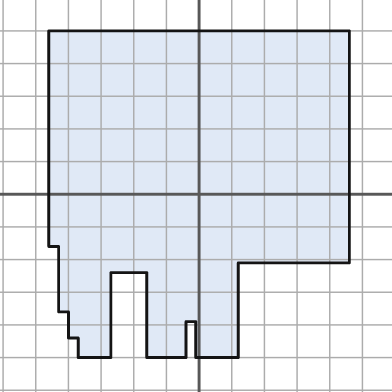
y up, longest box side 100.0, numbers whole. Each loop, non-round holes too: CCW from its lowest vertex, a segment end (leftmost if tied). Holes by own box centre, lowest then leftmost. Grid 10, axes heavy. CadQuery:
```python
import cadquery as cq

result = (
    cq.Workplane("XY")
    .moveTo(-37.0, -50.0)
    .lineTo(-27.0, -50.0)
    .lineTo(-27.0, -24.0)
    .lineTo(-16.0, -24.0)
    .lineTo(-16.0, -50.0)
    .lineTo(-4.0, -50.0)
    .lineTo(-4.0, -39.0)
    .lineTo(-1.0, -39.0)
    .lineTo(-1.0, -50.0)
    .lineTo(12.0, -50.0)
    .lineTo(12.0, -21.0)
    .lineTo(46.0, -21.0)
    .lineTo(46.0, 50.0)
    .lineTo(-46.0, 50.0)
    .lineTo(-46.0, -16.0)
    .lineTo(-43.0, -16.0)
    .lineTo(-43.0, -36.0)
    .lineTo(-40.0, -36.0)
    .lineTo(-40.0, -44.0)
    .lineTo(-37.0, -44.0)
    .close()
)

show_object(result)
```